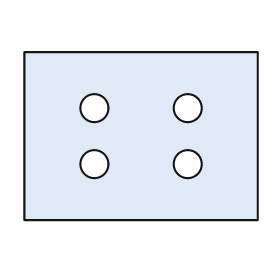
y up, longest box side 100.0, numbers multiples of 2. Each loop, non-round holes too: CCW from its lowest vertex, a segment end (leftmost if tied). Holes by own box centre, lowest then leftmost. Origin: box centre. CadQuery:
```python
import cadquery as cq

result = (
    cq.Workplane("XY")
    .moveTo(-50.0, -36.0)
    .lineTo(50.0, -36.0)
    .lineTo(50.0, 36.0)
    .lineTo(-50.0, 36.0)
    .close()
    .moveTo(-20.0, -12.0)
    .circle(6.0)
    .moveTo(20.0, -12.0)
    .circle(6.0)
    .moveTo(-20.0, 12.0)
    .circle(6.0)
    .moveTo(20.0, 12.0)
    .circle(6.0)
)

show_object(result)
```